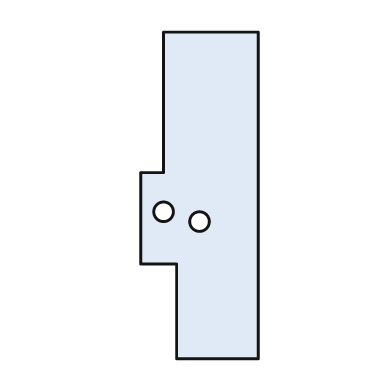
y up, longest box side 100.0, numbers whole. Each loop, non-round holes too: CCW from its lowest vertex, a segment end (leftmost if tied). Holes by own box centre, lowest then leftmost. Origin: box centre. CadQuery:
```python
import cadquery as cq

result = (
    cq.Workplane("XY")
    .moveTo(-7.0, -50.0)
    .lineTo(18.0, -50.0)
    .lineTo(18.0, 50.0)
    .lineTo(-11.0, 50.0)
    .lineTo(-11.0, 7.0)
    .lineTo(-18.0, 7.0)
    .lineTo(-18.0, -21.0)
    .lineTo(-7.0, -21.0)
    .close()
    .moveTo(0.0, -8.0)
    .circle(3.0)
    .moveTo(-11.0, -5.0)
    .circle(3.0)
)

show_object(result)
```